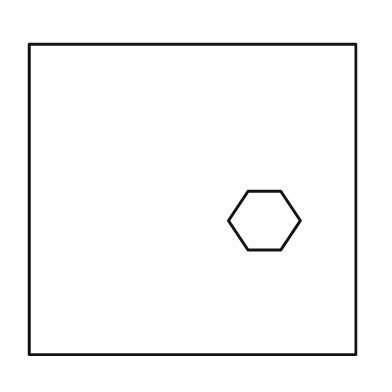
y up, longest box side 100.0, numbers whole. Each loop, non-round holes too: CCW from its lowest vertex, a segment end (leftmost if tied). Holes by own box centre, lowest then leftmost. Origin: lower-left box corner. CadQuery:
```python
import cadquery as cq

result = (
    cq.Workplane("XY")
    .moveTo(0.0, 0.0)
    .lineTo(100.0, 0.0)
    .lineTo(100.0, 95.0)
    .lineTo(0.0, 95.0)
    .close()
    .moveTo(67.0, 32.0)
    .lineTo(77.0, 32.0)
    .lineTo(83.0, 41.0)
    .lineTo(77.0, 50.0)
    .lineTo(67.0, 50.0)
    .lineTo(61.0, 41.0)
    .close()
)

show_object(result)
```